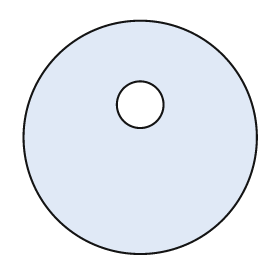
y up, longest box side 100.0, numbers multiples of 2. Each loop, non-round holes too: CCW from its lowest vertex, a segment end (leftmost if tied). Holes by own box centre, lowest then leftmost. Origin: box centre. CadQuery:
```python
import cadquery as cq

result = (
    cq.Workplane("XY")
    .moveTo(0.0, 0.0)
    .circle(50.0)
    .moveTo(0.0, 14.0)
    .circle(10.0)
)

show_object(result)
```